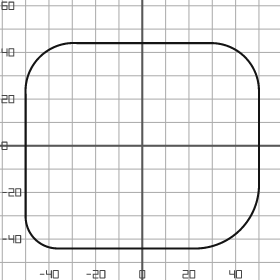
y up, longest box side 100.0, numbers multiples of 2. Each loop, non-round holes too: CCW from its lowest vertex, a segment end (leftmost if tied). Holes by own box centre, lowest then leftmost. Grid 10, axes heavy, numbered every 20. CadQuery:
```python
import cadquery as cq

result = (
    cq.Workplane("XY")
    .moveTo(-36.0, -44.0)
    .lineTo(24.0, -44.0)
    .threePointArc((42.0, -36.0), (50.0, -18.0))
    .lineTo(50.0, 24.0)
    .threePointArc((44.0, 38.0), (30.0, 44.0))
    .lineTo(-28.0, 44.0)
    .threePointArc((-44.0, 38.0), (-50.0, 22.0))
    .lineTo(-50.0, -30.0)
    .threePointArc((-46.0, -40.0), (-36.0, -44.0))
    .close()
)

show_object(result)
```